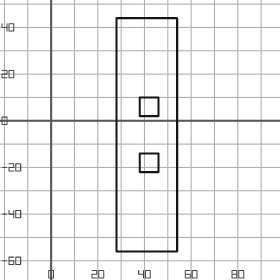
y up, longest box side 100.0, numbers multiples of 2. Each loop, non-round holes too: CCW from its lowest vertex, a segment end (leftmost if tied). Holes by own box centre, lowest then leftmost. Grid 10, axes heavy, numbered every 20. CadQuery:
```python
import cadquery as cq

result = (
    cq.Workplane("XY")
    .moveTo(28.0, -56.0)
    .lineTo(54.0, -56.0)
    .lineTo(54.0, 44.0)
    .lineTo(28.0, 44.0)
    .close()
    .moveTo(38.0, -22.0)
    .lineTo(46.0, -22.0)
    .lineTo(46.0, -14.0)
    .lineTo(38.0, -14.0)
    .close()
    .moveTo(38.0, 2.0)
    .lineTo(46.0, 2.0)
    .lineTo(46.0, 10.0)
    .lineTo(38.0, 10.0)
    .close()
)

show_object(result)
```